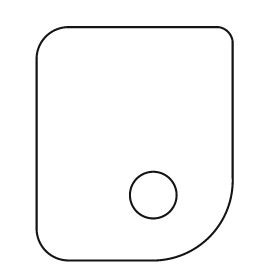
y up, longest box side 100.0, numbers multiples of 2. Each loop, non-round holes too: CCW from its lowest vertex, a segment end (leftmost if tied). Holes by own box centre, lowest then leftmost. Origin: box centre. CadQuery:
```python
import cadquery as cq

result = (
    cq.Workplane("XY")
    .moveTo(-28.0, -50.0)
    .lineTo(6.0, -50.0)
    .threePointArc((32.0, -40.0), (42.0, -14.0))
    .lineTo(42.0, 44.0)
    .threePointArc((40.0, 48.0), (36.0, 50.0))
    .lineTo(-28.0, 50.0)
    .threePointArc((-38.0, 46.0), (-42.0, 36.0))
    .lineTo(-42.0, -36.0)
    .threePointArc((-38.0, -46.0), (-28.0, -50.0))
    .close()
    .moveTo(8.0, -22.0)
    .circle(10.0)
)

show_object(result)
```